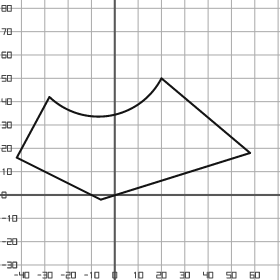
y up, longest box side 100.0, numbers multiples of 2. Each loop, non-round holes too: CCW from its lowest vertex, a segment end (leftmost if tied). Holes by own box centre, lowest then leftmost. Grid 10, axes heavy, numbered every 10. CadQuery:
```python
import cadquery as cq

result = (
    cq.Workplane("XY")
    .moveTo(-6.0, -2.0)
    .lineTo(58.0, 18.0)
    .lineTo(20.0, 50.0)
    .threePointArc((-2.0, 34.0), (-28.0, 42.0))
    .lineTo(-42.0, 16.0)
    .close()
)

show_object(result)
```